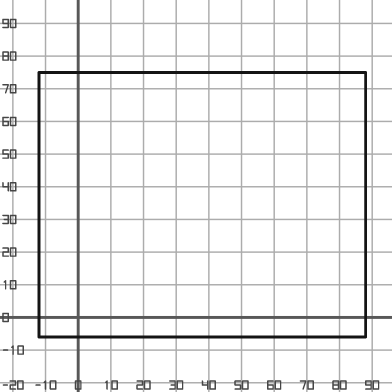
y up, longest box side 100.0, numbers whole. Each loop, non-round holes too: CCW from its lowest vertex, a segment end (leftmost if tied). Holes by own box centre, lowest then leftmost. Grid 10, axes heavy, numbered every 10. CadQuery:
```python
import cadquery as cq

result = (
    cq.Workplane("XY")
    .moveTo(-12.0, -6.0)
    .lineTo(88.0, -6.0)
    .lineTo(88.0, 75.0)
    .lineTo(-12.0, 75.0)
    .close()
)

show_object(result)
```